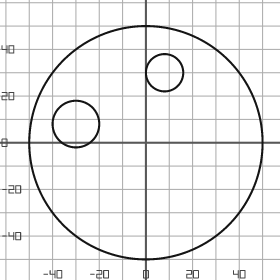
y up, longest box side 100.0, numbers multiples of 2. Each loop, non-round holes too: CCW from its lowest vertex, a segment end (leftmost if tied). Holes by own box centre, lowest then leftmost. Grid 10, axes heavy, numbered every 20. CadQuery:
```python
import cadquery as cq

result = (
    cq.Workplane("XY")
    .moveTo(0.0, 0.0)
    .circle(50.0)
    .moveTo(-30.0, 8.0)
    .circle(10.0)
    .moveTo(8.0, 30.0)
    .circle(8.0)
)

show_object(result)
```